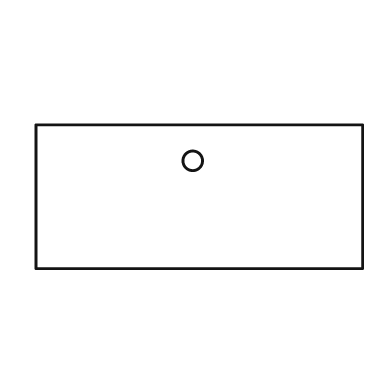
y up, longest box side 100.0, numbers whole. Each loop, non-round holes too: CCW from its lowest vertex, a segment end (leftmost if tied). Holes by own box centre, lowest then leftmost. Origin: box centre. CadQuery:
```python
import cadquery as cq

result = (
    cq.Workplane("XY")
    .moveTo(-50.0, -22.0)
    .lineTo(50.0, -22.0)
    .lineTo(50.0, 22.0)
    .lineTo(-50.0, 22.0)
    .close()
    .moveTo(-2.0, 11.0)
    .circle(3.0)
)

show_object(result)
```